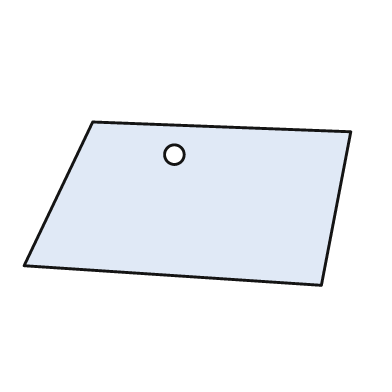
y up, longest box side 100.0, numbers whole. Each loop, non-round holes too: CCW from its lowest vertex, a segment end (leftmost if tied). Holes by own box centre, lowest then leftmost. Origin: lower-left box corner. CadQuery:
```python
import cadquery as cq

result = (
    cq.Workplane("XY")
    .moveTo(91.0, 0.0)
    .lineTo(100.0, 47.0)
    .lineTo(21.0, 50.0)
    .lineTo(0.0, 6.0)
    .close()
    .moveTo(46.0, 40.0)
    .circle(3.0)
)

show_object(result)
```